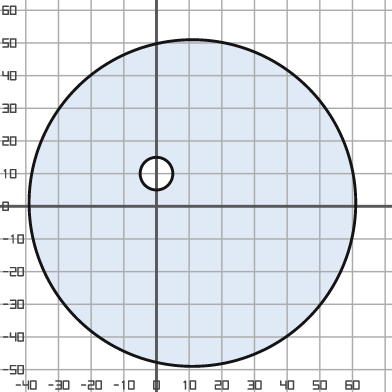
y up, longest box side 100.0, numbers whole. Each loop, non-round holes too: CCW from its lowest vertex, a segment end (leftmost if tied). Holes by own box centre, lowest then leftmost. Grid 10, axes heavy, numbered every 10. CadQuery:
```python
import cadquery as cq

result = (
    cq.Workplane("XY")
    .moveTo(11.0, 1.0)
    .circle(50.0)
    .moveTo(0.0, 10.0)
    .circle(5.0)
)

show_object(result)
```